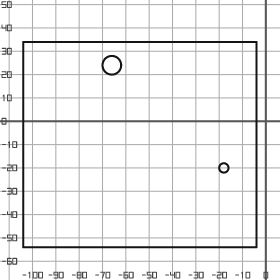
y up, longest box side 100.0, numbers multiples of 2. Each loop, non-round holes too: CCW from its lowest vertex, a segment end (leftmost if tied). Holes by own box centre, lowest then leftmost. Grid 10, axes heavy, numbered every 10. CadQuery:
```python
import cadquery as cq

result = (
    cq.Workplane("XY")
    .moveTo(-104.0, -54.0)
    .lineTo(-4.0, -54.0)
    .lineTo(-4.0, 34.0)
    .lineTo(-104.0, 34.0)
    .close()
    .moveTo(-18.0, -20.0)
    .circle(2.0)
    .moveTo(-66.0, 24.0)
    .circle(4.0)
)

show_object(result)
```